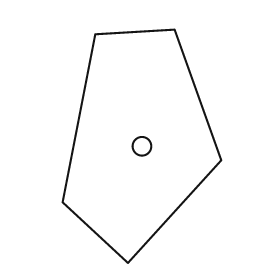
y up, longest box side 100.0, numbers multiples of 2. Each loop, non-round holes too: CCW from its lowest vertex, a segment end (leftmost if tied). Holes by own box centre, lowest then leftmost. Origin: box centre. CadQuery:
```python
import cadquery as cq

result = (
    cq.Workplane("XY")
    .moveTo(-6.0, -50.0)
    .lineTo(34.0, -6.0)
    .lineTo(14.0, 50.0)
    .lineTo(-20.0, 48.0)
    .lineTo(-34.0, -24.0)
    .close()
    .moveTo(0.0, 0.0)
    .circle(4.0)
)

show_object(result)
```